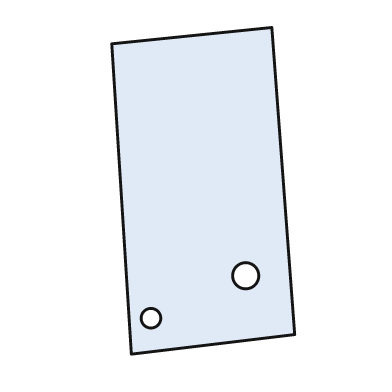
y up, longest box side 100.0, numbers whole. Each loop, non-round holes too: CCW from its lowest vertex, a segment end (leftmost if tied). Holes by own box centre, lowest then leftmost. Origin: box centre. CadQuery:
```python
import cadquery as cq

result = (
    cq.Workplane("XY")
    .moveTo(-22.0, -50.0)
    .lineTo(28.0, -44.0)
    .lineTo(21.0, 50.0)
    .lineTo(-28.0, 45.0)
    .close()
    .moveTo(-16.0, -39.0)
    .circle(3.0)
    .moveTo(13.0, -26.0)
    .circle(4.0)
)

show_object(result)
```